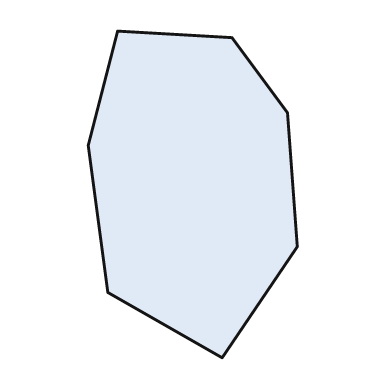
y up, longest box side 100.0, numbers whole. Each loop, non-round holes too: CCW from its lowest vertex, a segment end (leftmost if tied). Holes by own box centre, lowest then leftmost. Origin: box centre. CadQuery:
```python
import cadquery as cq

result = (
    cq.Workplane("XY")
    .moveTo(9.0, -50.0)
    .lineTo(32.0, -16.0)
    .lineTo(29.0, 25.0)
    .lineTo(12.0, 48.0)
    .lineTo(-23.0, 50.0)
    .lineTo(-32.0, 15.0)
    .lineTo(-26.0, -30.0)
    .close()
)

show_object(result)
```